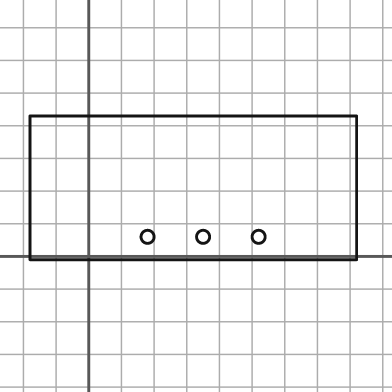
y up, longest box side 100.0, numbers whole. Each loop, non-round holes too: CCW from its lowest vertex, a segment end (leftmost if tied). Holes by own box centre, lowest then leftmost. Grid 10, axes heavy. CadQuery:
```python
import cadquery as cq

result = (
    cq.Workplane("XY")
    .moveTo(-18.0, -1.0)
    .lineTo(82.0, -1.0)
    .lineTo(82.0, 43.0)
    .lineTo(-18.0, 43.0)
    .close()
    .moveTo(18.0, 6.0)
    .circle(2.0)
    .moveTo(35.0, 6.0)
    .circle(2.0)
    .moveTo(52.0, 6.0)
    .circle(2.0)
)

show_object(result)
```